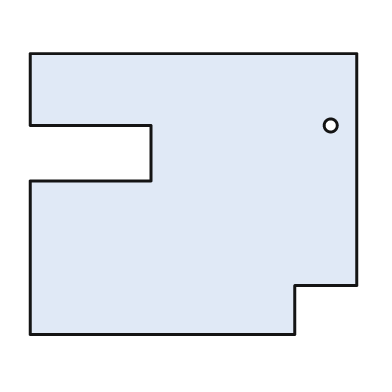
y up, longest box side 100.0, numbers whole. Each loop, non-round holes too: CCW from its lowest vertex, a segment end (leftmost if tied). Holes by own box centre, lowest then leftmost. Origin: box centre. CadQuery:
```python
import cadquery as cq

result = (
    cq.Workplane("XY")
    .moveTo(-50.0, -43.0)
    .lineTo(31.0, -43.0)
    .lineTo(31.0, -28.0)
    .lineTo(50.0, -28.0)
    .lineTo(50.0, 43.0)
    .lineTo(-50.0, 43.0)
    .lineTo(-50.0, 21.0)
    .lineTo(-13.0, 21.0)
    .lineTo(-13.0, 4.0)
    .lineTo(-50.0, 4.0)
    .close()
    .moveTo(42.0, 21.0)
    .circle(2.0)
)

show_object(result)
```